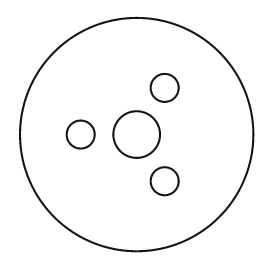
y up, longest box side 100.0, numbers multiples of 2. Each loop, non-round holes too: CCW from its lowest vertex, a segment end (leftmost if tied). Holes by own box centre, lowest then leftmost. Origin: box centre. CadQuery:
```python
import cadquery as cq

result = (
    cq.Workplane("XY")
    .moveTo(0.0, 0.0)
    .circle(50.0)
    .moveTo(12.0, -20.0)
    .circle(6.0)
    .moveTo(-24.0, 0.0)
    .circle(6.0)
    .moveTo(0.0, 0.0)
    .circle(10.0)
    .moveTo(12.0, 20.0)
    .circle(6.0)
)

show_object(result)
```